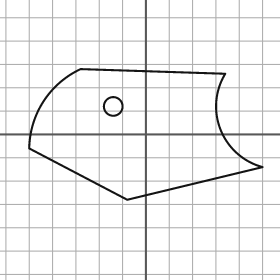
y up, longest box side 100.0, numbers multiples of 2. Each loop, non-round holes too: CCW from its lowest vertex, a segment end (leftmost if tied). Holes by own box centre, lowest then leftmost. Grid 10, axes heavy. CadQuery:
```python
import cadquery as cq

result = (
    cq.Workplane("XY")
    .moveTo(-8.0, -28.0)
    .lineTo(50.0, -14.0)
    .threePointArc((32.0, 2.0), (34.0, 26.0))
    .lineTo(-28.0, 28.0)
    .threePointArc((-44.0, 14.0), (-50.0, -6.0))
    .close()
    .moveTo(-14.0, 12.0)
    .circle(4.0)
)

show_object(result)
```